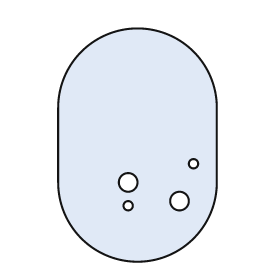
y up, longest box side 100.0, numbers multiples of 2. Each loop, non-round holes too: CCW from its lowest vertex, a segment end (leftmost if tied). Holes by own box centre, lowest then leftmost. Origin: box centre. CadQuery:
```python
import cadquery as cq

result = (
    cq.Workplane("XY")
    .moveTo(-34.0, -16.0)
    .threePointArc((0.0, -50.0), (34.0, -16.0))
    .lineTo(34.0, 16.0)
    .threePointArc((0.0, 50.0), (-34.0, 16.0))
    .close()
    .moveTo(-4.0, -26.0)
    .circle(2.0)
    .moveTo(18.0, -24.0)
    .circle(4.0)
    .moveTo(-4.0, -16.0)
    .circle(4.0)
    .moveTo(24.0, -8.0)
    .circle(2.0)
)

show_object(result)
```